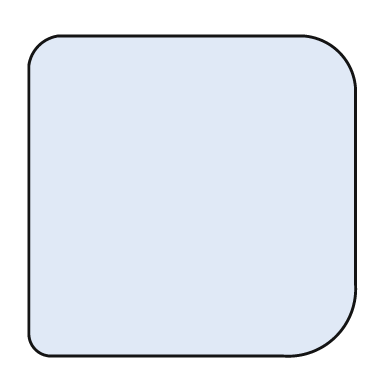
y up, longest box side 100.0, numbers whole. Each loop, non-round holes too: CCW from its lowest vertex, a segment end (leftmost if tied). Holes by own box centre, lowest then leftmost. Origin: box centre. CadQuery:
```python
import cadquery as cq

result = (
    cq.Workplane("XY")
    .moveTo(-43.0, -49.0)
    .lineTo(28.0, -49.0)
    .threePointArc((44.0, -43.0), (50.0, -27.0))
    .lineTo(50.0, 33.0)
    .threePointArc((45.0, 44.0), (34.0, 49.0))
    .lineTo(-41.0, 49.0)
    .threePointArc((-47.0, 46.0), (-50.0, 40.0))
    .lineTo(-50.0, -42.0)
    .threePointArc((-48.0, -47.0), (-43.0, -49.0))
    .close()
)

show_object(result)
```